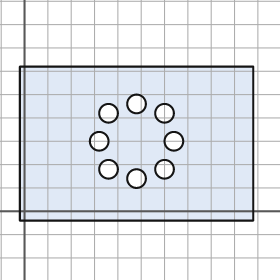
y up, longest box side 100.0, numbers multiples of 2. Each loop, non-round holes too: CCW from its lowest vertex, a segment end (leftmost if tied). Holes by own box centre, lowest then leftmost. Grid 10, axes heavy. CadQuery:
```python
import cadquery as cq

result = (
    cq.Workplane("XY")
    .moveTo(-2.0, -4.0)
    .lineTo(98.0, -4.0)
    .lineTo(98.0, 62.0)
    .lineTo(-2.0, 62.0)
    .close()
    .moveTo(48.0, 14.0)
    .circle(4.0)
    .moveTo(36.0, 18.0)
    .circle(4.0)
    .moveTo(60.0, 18.0)
    .circle(4.0)
    .moveTo(32.0, 30.0)
    .circle(4.0)
    .moveTo(64.0, 30.0)
    .circle(4.0)
    .moveTo(36.0, 42.0)
    .circle(4.0)
    .moveTo(60.0, 42.0)
    .circle(4.0)
    .moveTo(48.0, 46.0)
    .circle(4.0)
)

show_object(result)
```